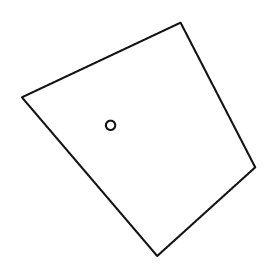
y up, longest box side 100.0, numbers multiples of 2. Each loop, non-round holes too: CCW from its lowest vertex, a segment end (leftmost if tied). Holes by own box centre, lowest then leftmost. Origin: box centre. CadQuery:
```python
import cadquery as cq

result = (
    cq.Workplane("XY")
    .moveTo(8.0, -50.0)
    .lineTo(50.0, -12.0)
    .lineTo(18.0, 50.0)
    .lineTo(-50.0, 18.0)
    .close()
    .moveTo(-12.0, 6.0)
    .circle(2.0)
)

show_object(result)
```